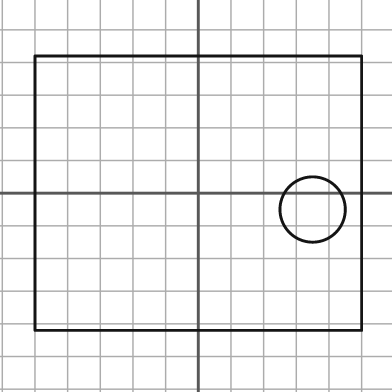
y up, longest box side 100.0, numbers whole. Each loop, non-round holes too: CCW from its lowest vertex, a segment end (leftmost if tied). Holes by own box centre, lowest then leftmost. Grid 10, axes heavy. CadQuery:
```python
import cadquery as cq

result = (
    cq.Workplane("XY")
    .moveTo(-50.0, -42.0)
    .lineTo(50.0, -42.0)
    .lineTo(50.0, 42.0)
    .lineTo(-50.0, 42.0)
    .close()
    .moveTo(35.0, -5.0)
    .circle(10.0)
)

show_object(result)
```